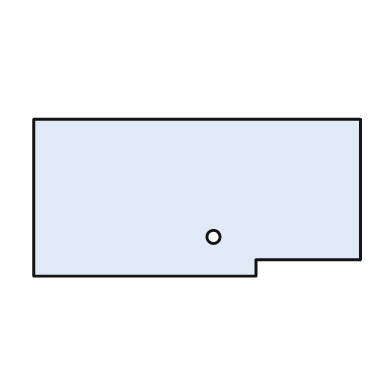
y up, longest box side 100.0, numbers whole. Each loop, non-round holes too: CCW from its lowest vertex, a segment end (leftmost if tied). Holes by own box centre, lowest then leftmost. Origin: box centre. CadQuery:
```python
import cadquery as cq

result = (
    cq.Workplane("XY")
    .moveTo(-50.0, -24.0)
    .lineTo(18.0, -24.0)
    .lineTo(18.0, -19.0)
    .lineTo(50.0, -19.0)
    .lineTo(50.0, 24.0)
    .lineTo(-50.0, 24.0)
    .close()
    .moveTo(5.0, -12.0)
    .circle(2.0)
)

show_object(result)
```